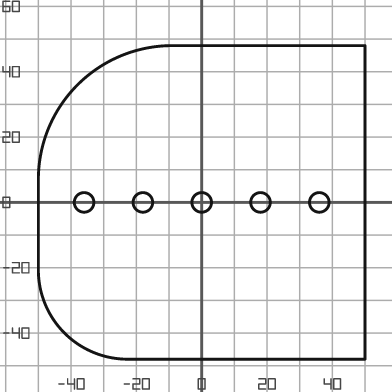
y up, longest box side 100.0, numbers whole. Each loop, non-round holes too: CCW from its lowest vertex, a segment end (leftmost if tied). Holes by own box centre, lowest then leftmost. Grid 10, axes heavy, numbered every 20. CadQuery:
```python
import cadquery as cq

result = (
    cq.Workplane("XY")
    .moveTo(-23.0, -48.0)
    .lineTo(50.0, -48.0)
    .lineTo(50.0, 48.0)
    .lineTo(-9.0, 48.0)
    .threePointArc((-38.0, 36.0), (-50.0, 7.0))
    .lineTo(-50.0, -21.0)
    .threePointArc((-42.0, -40.0), (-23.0, -48.0))
    .close()
    .moveTo(-36.0, 0.0)
    .circle(3.0)
    .moveTo(-18.0, 0.0)
    .circle(3.0)
    .moveTo(0.0, 0.0)
    .circle(3.0)
    .moveTo(18.0, 0.0)
    .circle(3.0)
    .moveTo(36.0, 0.0)
    .circle(3.0)
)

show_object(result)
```